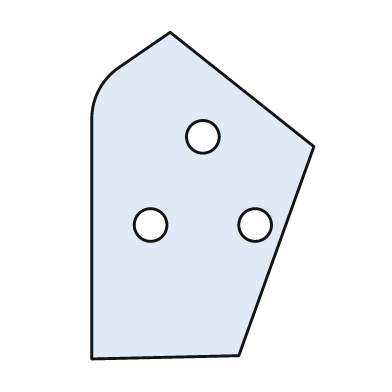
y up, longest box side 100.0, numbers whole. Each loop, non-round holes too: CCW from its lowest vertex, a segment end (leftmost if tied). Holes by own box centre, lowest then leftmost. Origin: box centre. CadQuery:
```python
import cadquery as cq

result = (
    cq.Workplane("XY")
    .moveTo(-34.0, -50.0)
    .lineTo(11.0, -49.0)
    .lineTo(34.0, 15.0)
    .lineTo(-10.0, 50.0)
    .lineTo(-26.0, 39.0)
    .threePointArc((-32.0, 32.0), (-34.0, 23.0))
    .close()
    .moveTo(-16.0, -9.0)
    .circle(5.0)
    .moveTo(16.0, -9.0)
    .circle(5.0)
    .moveTo(0.0, 18.0)
    .circle(5.0)
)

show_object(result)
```